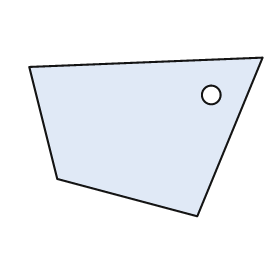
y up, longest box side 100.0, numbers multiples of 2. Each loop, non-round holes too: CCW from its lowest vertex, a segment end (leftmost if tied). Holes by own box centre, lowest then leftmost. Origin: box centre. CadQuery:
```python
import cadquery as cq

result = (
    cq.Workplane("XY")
    .moveTo(22.0, -34.0)
    .lineTo(50.0, 34.0)
    .lineTo(-50.0, 30.0)
    .lineTo(-38.0, -18.0)
    .close()
    .moveTo(28.0, 18.0)
    .circle(4.0)
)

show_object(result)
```